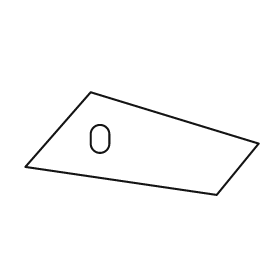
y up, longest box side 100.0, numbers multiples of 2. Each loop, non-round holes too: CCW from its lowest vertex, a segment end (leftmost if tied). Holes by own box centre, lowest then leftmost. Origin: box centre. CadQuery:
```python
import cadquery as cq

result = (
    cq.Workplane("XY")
    .moveTo(32.0, -22.0)
    .lineTo(50.0, 0.0)
    .lineTo(-22.0, 22.0)
    .lineTo(-50.0, -10.0)
    .close()
    .moveTo(-22.0, 0.0)
    .threePointArc((-18.0, -4.0), (-14.0, 0.0))
    .lineTo(-14.0, 4.0)
    .threePointArc((-18.0, 8.0), (-22.0, 4.0))
    .close()
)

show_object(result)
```